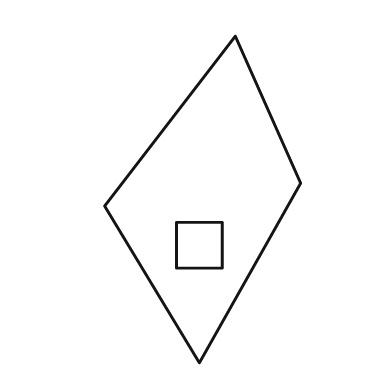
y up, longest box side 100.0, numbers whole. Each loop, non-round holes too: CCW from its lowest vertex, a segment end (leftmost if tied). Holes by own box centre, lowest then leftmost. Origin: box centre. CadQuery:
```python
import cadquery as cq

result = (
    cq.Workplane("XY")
    .moveTo(-1.0, -50.0)
    .lineTo(30.0, 5.0)
    .lineTo(10.0, 50.0)
    .lineTo(-30.0, -2.0)
    .close()
    .moveTo(-8.0, -21.0)
    .lineTo(6.0, -21.0)
    .lineTo(6.0, -7.0)
    .lineTo(-8.0, -7.0)
    .close()
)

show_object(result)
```